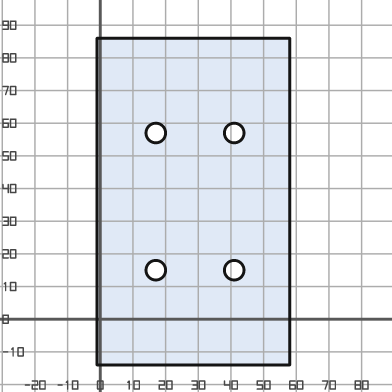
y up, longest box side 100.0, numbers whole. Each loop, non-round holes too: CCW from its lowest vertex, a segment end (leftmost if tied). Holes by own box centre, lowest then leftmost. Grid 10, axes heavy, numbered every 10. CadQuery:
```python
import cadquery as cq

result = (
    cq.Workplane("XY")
    .moveTo(-1.0, -14.0)
    .lineTo(58.0, -14.0)
    .lineTo(58.0, 86.0)
    .lineTo(-1.0, 86.0)
    .close()
    .moveTo(17.0, 15.0)
    .circle(3.0)
    .moveTo(41.0, 15.0)
    .circle(3.0)
    .moveTo(17.0, 57.0)
    .circle(3.0)
    .moveTo(41.0, 57.0)
    .circle(3.0)
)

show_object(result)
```